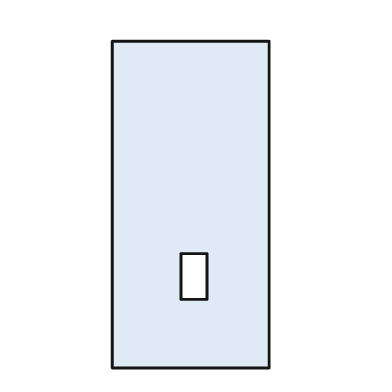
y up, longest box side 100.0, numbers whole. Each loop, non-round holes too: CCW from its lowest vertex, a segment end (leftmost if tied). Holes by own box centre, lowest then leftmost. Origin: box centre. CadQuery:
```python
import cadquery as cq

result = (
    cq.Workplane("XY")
    .moveTo(-24.0, -50.0)
    .lineTo(24.0, -50.0)
    .lineTo(24.0, 50.0)
    .lineTo(-24.0, 50.0)
    .close()
    .moveTo(-3.0, -29.0)
    .lineTo(5.0, -29.0)
    .lineTo(5.0, -15.0)
    .lineTo(-3.0, -15.0)
    .close()
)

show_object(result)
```